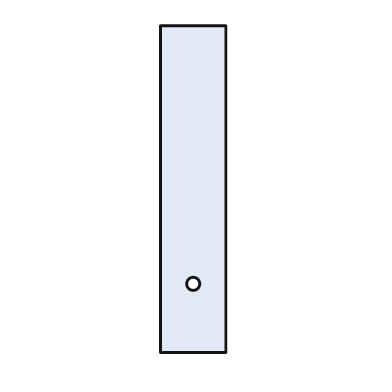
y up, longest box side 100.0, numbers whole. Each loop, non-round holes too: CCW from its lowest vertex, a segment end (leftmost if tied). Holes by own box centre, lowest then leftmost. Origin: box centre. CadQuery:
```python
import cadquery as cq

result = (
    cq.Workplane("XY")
    .moveTo(-10.0, -50.0)
    .lineTo(10.0, -50.0)
    .lineTo(10.0, 50.0)
    .lineTo(-10.0, 50.0)
    .close()
    .moveTo(0.0, -29.0)
    .circle(2.0)
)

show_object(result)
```